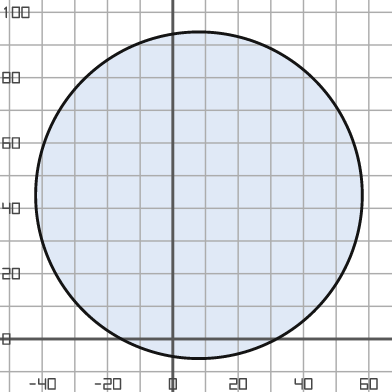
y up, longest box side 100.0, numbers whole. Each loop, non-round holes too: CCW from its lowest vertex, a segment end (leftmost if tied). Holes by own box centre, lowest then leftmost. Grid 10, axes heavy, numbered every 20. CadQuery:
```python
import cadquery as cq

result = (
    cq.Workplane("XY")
    .moveTo(8.0, 44.0)
    .circle(50.0)
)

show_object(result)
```